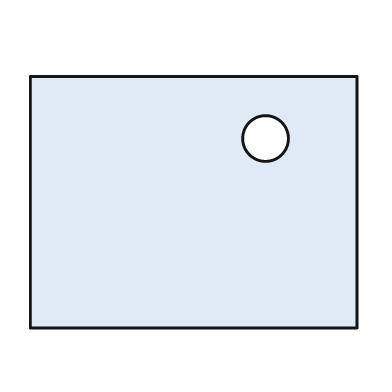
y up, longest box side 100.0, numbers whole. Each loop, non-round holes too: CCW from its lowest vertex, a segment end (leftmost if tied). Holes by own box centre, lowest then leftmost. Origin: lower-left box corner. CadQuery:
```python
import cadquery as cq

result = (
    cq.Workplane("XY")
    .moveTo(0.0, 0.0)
    .lineTo(100.0, 0.0)
    .lineTo(100.0, 77.0)
    .lineTo(0.0, 77.0)
    .close()
    .moveTo(72.0, 58.0)
    .circle(7.0)
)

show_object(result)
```